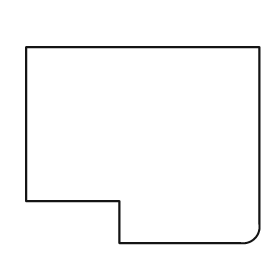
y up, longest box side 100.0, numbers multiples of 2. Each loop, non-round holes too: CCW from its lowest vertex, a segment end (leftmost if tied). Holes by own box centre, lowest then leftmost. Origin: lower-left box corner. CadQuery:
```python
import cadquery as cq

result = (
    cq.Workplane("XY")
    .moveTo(40.0, 0.0)
    .lineTo(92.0, 0.0)
    .threePointArc((98.0, 2.0), (100.0, 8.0))
    .lineTo(100.0, 84.0)
    .lineTo(0.0, 84.0)
    .lineTo(0.0, 18.0)
    .lineTo(40.0, 18.0)
    .close()
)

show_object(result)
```